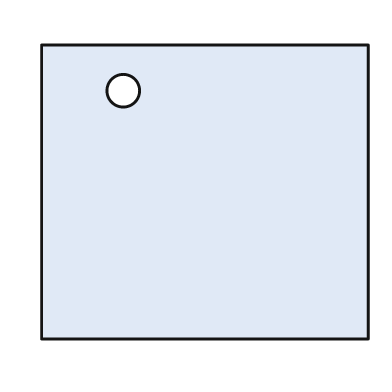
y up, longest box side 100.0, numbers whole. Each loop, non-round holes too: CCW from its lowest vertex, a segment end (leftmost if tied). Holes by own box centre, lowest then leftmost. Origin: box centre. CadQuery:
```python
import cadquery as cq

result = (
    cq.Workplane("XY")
    .moveTo(-50.0, -45.0)
    .lineTo(50.0, -45.0)
    .lineTo(50.0, 45.0)
    .lineTo(-50.0, 45.0)
    .close()
    .moveTo(-25.0, 31.0)
    .circle(5.0)
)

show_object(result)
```